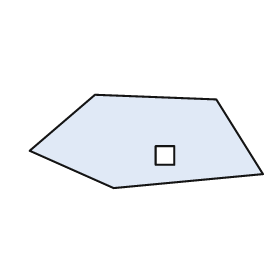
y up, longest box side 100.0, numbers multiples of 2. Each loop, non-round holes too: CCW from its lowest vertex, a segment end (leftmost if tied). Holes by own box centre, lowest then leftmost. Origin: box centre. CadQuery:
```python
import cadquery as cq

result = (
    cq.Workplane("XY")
    .moveTo(-14.0, -20.0)
    .lineTo(50.0, -14.0)
    .lineTo(30.0, 18.0)
    .lineTo(-22.0, 20.0)
    .lineTo(-50.0, -4.0)
    .close()
    .moveTo(4.0, -10.0)
    .lineTo(12.0, -10.0)
    .lineTo(12.0, -2.0)
    .lineTo(4.0, -2.0)
    .close()
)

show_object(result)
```